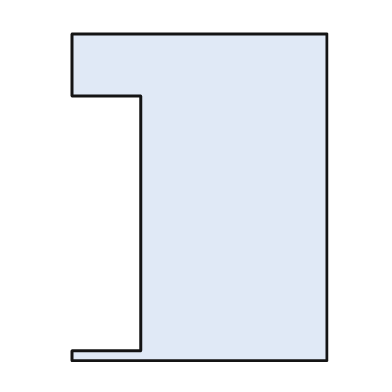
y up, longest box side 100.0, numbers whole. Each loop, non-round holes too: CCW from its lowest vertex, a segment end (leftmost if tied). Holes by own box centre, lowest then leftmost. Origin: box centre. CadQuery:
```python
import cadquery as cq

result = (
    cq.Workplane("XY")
    .moveTo(-39.0, -50.0)
    .lineTo(39.0, -50.0)
    .lineTo(39.0, 50.0)
    .lineTo(-39.0, 50.0)
    .lineTo(-39.0, 31.0)
    .lineTo(-18.0, 31.0)
    .lineTo(-18.0, -47.0)
    .lineTo(-39.0, -47.0)
    .close()
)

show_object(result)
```